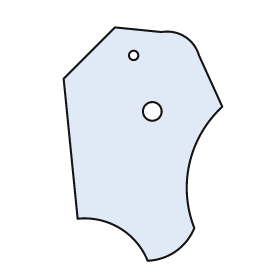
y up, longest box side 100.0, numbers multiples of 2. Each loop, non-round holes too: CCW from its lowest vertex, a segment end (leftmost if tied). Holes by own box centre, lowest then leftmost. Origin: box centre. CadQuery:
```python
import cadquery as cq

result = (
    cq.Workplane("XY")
    .moveTo(2.0, -50.0)
    .threePointArc((14.0, -46.0), (22.0, -36.0))
    .threePointArc((20.0, -8.0), (34.0, 16.0))
    .lineTo(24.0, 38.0)
    .threePointArc((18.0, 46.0), (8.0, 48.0))
    .lineTo(-12.0, 50.0)
    .lineTo(-34.0, 28.0)
    .lineTo(-28.0, -32.0)
    .threePointArc((-10.0, -36.0), (2.0, -50.0))
    .close()
    .moveTo(4.0, 14.0)
    .circle(4.0)
    .moveTo(-4.0, 38.0)
    .circle(2.0)
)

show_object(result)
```